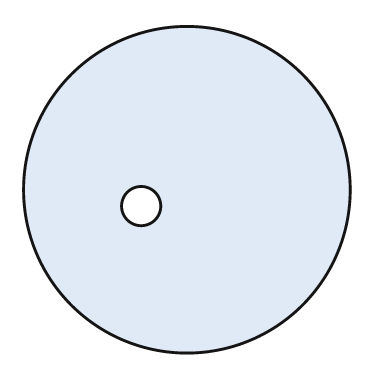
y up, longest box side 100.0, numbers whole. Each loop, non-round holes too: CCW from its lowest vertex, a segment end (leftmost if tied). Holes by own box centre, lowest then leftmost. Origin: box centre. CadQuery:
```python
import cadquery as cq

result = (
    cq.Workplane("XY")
    .moveTo(0.0, 0.0)
    .circle(50.0)
    .moveTo(-14.0, -5.0)
    .circle(6.0)
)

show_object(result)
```